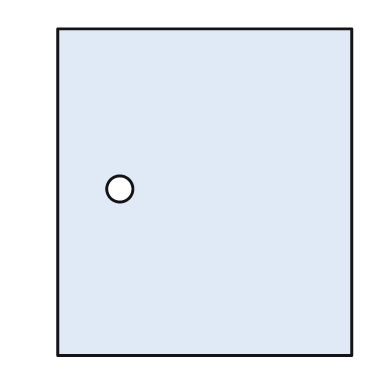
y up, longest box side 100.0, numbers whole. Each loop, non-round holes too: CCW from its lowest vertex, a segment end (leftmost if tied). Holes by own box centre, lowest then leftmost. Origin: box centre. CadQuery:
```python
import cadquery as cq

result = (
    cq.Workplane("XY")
    .moveTo(-45.0, -50.0)
    .lineTo(45.0, -50.0)
    .lineTo(45.0, 50.0)
    .lineTo(-45.0, 50.0)
    .close()
    .moveTo(-26.0, 1.0)
    .circle(4.0)
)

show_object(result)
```